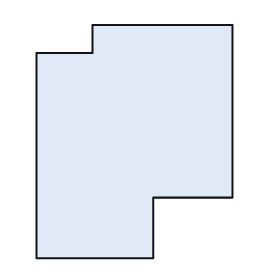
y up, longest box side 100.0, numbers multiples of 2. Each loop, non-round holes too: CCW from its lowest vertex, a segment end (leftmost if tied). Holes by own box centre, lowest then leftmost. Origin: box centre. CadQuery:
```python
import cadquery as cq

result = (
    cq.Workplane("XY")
    .moveTo(-42.0, -50.0)
    .lineTo(8.0, -50.0)
    .lineTo(8.0, -24.0)
    .lineTo(42.0, -24.0)
    .lineTo(42.0, 50.0)
    .lineTo(-18.0, 50.0)
    .lineTo(-18.0, 38.0)
    .lineTo(-42.0, 38.0)
    .close()
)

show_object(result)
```